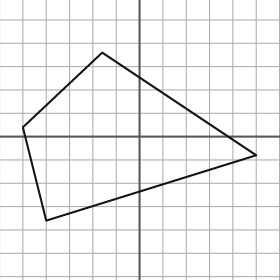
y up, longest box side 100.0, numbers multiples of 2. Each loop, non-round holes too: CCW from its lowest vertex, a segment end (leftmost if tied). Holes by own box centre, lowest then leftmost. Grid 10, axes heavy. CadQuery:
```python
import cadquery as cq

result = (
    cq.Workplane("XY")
    .moveTo(-40.0, -36.0)
    .lineTo(50.0, -8.0)
    .lineTo(-16.0, 36.0)
    .lineTo(-50.0, 4.0)
    .close()
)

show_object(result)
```